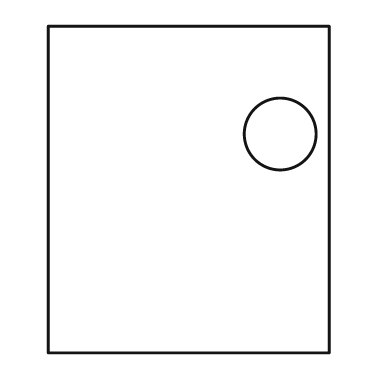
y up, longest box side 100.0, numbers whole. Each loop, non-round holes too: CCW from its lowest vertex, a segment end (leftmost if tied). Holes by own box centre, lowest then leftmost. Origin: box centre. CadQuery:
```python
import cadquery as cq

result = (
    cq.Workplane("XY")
    .moveTo(-43.0, -50.0)
    .lineTo(43.0, -50.0)
    .lineTo(43.0, 50.0)
    .lineTo(-43.0, 50.0)
    .close()
    .moveTo(28.0, 17.0)
    .circle(11.0)
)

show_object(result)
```